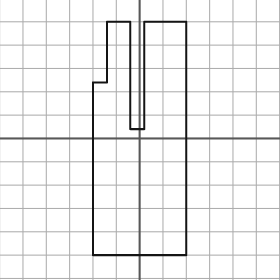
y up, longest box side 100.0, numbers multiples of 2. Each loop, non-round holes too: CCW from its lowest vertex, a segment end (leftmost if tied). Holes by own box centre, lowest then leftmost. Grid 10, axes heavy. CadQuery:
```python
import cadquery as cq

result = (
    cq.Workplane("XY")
    .moveTo(-20.0, -50.0)
    .lineTo(20.0, -50.0)
    .lineTo(20.0, 50.0)
    .lineTo(2.0, 50.0)
    .lineTo(2.0, 4.0)
    .lineTo(-4.0, 4.0)
    .lineTo(-4.0, 50.0)
    .lineTo(-14.0, 50.0)
    .lineTo(-14.0, 24.0)
    .lineTo(-20.0, 24.0)
    .close()
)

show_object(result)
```